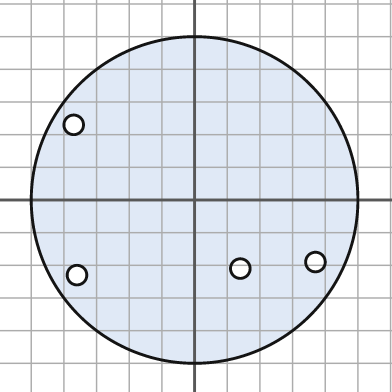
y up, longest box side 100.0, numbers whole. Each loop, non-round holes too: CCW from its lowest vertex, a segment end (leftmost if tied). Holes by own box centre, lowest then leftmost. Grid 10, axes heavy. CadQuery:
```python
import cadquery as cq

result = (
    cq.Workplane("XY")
    .moveTo(0.0, 0.0)
    .circle(50.0)
    .moveTo(-36.0, -23.0)
    .circle(3.0)
    .moveTo(14.0, -21.0)
    .circle(3.0)
    .moveTo(37.0, -19.0)
    .circle(3.0)
    .moveTo(-37.0, 23.0)
    .circle(3.0)
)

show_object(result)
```